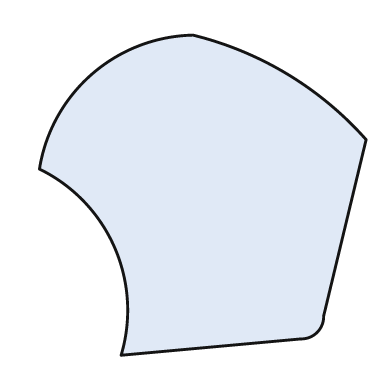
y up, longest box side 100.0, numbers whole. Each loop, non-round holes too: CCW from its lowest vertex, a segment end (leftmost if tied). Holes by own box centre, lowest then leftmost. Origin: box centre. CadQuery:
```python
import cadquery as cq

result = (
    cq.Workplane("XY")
    .moveTo(-25.0, -49.0)
    .lineTo(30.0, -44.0)
    .threePointArc((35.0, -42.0), (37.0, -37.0))
    .lineTo(50.0, 17.0)
    .threePointArc((26.0, 37.0), (-3.0, 49.0))
    .threePointArc((-34.0, 37.0), (-50.0, 8.0))
    .threePointArc((-27.0, -16.0), (-25.0, -49.0))
    .close()
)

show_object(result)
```